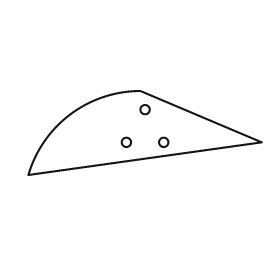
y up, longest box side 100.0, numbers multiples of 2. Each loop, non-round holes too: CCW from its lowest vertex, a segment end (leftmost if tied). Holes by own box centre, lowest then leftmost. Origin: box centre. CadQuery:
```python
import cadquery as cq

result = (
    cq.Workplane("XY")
    .moveTo(-50.0, -18.0)
    .lineTo(50.0, -4.0)
    .lineTo(-2.0, 18.0)
    .threePointArc((-32.0, 8.0), (-50.0, -18.0))
    .close()
    .moveTo(-8.0, -4.0)
    .circle(2.0)
    .moveTo(8.0, -4.0)
    .circle(2.0)
    .moveTo(0.0, 10.0)
    .circle(2.0)
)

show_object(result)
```